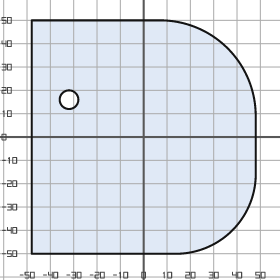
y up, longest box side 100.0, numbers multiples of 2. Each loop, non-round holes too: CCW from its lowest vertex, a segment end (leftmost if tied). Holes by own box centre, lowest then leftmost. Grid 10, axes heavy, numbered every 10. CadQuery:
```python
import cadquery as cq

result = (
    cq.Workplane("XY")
    .moveTo(-48.0, -50.0)
    .lineTo(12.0, -50.0)
    .threePointArc((38.0, -40.0), (48.0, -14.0))
    .lineTo(48.0, 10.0)
    .threePointArc((36.0, 38.0), (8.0, 50.0))
    .lineTo(-48.0, 50.0)
    .close()
    .moveTo(-32.0, 16.0)
    .circle(4.0)
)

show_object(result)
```